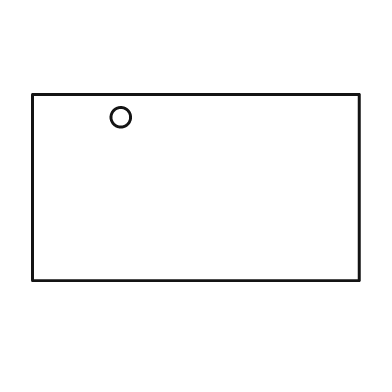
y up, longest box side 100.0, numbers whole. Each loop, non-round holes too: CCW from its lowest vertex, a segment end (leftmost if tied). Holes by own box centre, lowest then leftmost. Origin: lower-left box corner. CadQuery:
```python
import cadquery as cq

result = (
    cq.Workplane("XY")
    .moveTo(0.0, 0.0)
    .lineTo(100.0, 0.0)
    .lineTo(100.0, 57.0)
    .lineTo(0.0, 57.0)
    .close()
    .moveTo(27.0, 50.0)
    .circle(3.0)
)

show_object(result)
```